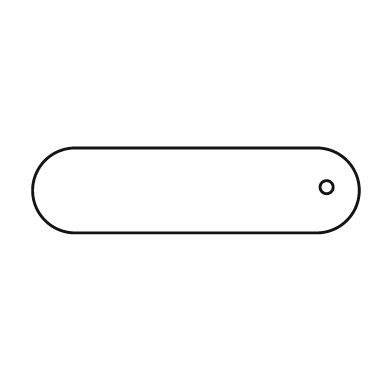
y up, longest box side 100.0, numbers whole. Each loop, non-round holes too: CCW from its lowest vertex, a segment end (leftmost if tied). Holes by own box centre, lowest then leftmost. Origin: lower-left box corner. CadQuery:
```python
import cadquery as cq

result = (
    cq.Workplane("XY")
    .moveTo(13.0, 0.0)
    .lineTo(87.0, 0.0)
    .threePointArc((100.0, 13.0), (87.0, 26.0))
    .lineTo(13.0, 26.0)
    .threePointArc((0.0, 13.0), (13.0, 0.0))
    .close()
    .moveTo(90.0, 14.0)
    .circle(2.0)
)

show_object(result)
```